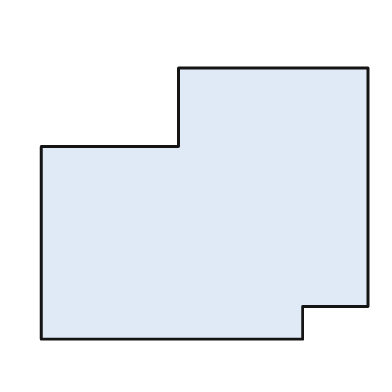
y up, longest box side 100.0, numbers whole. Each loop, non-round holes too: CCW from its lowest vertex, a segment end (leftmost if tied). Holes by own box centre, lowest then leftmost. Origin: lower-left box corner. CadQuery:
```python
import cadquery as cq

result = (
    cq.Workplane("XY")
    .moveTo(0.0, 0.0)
    .lineTo(80.0, 0.0)
    .lineTo(80.0, 10.0)
    .lineTo(100.0, 10.0)
    .lineTo(100.0, 83.0)
    .lineTo(42.0, 83.0)
    .lineTo(42.0, 59.0)
    .lineTo(0.0, 59.0)
    .close()
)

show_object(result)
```